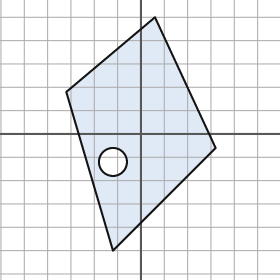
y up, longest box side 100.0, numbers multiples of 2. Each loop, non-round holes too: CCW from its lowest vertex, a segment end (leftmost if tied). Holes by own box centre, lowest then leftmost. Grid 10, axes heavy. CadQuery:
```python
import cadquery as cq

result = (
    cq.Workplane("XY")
    .moveTo(-12.0, -50.0)
    .lineTo(32.0, -6.0)
    .lineTo(6.0, 50.0)
    .lineTo(-32.0, 18.0)
    .close()
    .moveTo(-12.0, -12.0)
    .circle(6.0)
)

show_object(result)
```